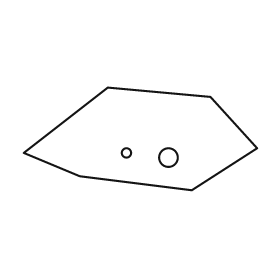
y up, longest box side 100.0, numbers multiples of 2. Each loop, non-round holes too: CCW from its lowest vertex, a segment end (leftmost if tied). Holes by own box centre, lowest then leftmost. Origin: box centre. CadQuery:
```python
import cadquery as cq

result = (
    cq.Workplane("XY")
    .moveTo(22.0, -22.0)
    .lineTo(50.0, -4.0)
    .lineTo(30.0, 18.0)
    .lineTo(-14.0, 22.0)
    .lineTo(-50.0, -6.0)
    .lineTo(-26.0, -16.0)
    .close()
    .moveTo(12.0, -8.0)
    .circle(4.0)
    .moveTo(-6.0, -6.0)
    .circle(2.0)
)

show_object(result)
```